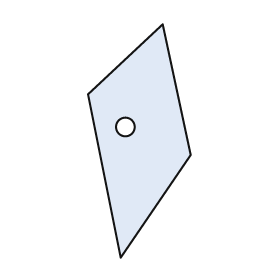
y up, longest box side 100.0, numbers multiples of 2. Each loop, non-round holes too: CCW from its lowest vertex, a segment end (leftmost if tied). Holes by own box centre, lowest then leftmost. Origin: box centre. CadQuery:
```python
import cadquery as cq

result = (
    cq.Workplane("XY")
    .moveTo(-8.0, -50.0)
    .lineTo(22.0, -6.0)
    .lineTo(10.0, 50.0)
    .lineTo(-22.0, 20.0)
    .close()
    .moveTo(-6.0, 6.0)
    .circle(4.0)
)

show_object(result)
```